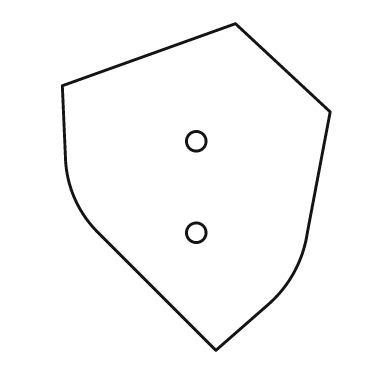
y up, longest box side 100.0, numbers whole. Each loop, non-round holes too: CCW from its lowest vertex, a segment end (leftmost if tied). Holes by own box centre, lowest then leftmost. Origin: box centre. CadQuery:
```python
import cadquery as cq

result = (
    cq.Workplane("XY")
    .moveTo(6.0, -50.0)
    .lineTo(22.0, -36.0)
    .threePointArc((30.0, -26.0), (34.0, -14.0))
    .lineTo(41.0, 23.0)
    .lineTo(12.0, 50.0)
    .lineTo(-41.0, 31.0)
    .lineTo(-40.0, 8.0)
    .threePointArc((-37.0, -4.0), (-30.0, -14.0))
    .close()
    .moveTo(0.0, -14.0)
    .circle(3.0)
    .moveTo(0.0, 14.0)
    .circle(3.0)
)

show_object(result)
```